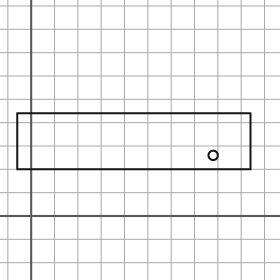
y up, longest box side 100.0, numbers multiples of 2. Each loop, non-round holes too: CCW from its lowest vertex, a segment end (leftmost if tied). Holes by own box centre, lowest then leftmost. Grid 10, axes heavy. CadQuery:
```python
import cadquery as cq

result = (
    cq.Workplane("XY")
    .moveTo(-6.0, 20.0)
    .lineTo(94.0, 20.0)
    .lineTo(94.0, 44.0)
    .lineTo(-6.0, 44.0)
    .close()
    .moveTo(78.0, 26.0)
    .circle(2.0)
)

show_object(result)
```